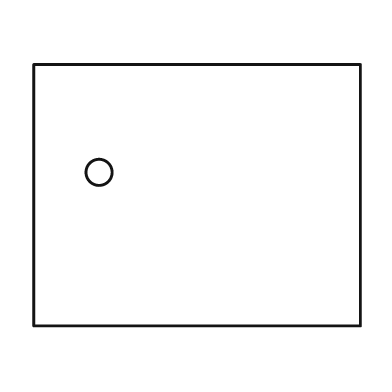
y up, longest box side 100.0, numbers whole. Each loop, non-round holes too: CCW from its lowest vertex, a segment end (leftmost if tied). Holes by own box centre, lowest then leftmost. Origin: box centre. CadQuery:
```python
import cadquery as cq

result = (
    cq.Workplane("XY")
    .moveTo(-50.0, -40.0)
    .lineTo(50.0, -40.0)
    .lineTo(50.0, 40.0)
    .lineTo(-50.0, 40.0)
    .close()
    .moveTo(-30.0, 7.0)
    .circle(4.0)
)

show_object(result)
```